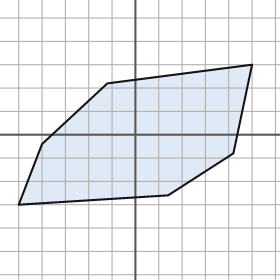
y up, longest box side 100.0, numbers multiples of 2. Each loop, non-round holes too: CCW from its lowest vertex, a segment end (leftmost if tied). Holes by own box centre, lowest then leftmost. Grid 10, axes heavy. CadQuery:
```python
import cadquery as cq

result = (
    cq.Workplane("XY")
    .moveTo(-50.0, -30.0)
    .lineTo(14.0, -26.0)
    .lineTo(42.0, -8.0)
    .lineTo(50.0, 30.0)
    .lineTo(-12.0, 22.0)
    .lineTo(-40.0, -4.0)
    .close()
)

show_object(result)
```